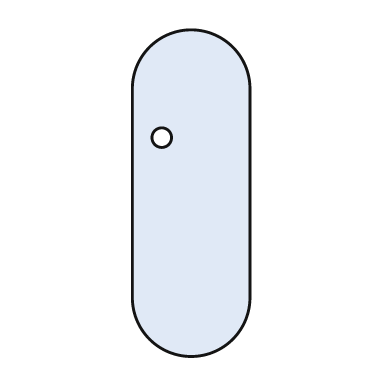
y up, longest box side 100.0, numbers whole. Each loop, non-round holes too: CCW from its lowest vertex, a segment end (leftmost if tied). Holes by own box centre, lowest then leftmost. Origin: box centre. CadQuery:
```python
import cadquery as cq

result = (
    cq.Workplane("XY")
    .moveTo(-18.0, -32.0)
    .threePointArc((0.0, -50.0), (18.0, -32.0))
    .lineTo(18.0, 32.0)
    .threePointArc((0.0, 50.0), (-18.0, 32.0))
    .close()
    .moveTo(-9.0, 17.0)
    .circle(3.0)
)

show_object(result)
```